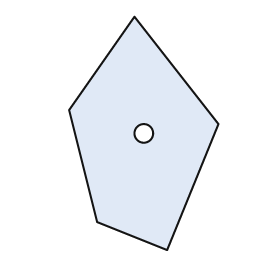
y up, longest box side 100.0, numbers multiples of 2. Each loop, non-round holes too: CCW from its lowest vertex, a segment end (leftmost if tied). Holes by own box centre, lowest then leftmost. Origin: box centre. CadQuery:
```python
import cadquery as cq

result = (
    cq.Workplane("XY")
    .moveTo(10.0, -50.0)
    .lineTo(32.0, 4.0)
    .lineTo(-4.0, 50.0)
    .lineTo(-32.0, 10.0)
    .lineTo(-20.0, -38.0)
    .close()
    .moveTo(0.0, 0.0)
    .circle(4.0)
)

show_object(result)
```